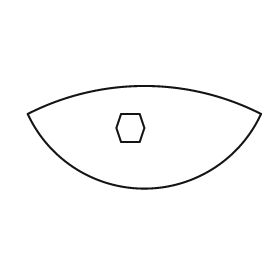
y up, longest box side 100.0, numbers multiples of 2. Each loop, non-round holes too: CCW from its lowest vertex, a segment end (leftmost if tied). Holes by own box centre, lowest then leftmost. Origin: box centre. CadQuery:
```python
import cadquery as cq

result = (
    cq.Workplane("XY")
    .moveTo(-50.0, 10.0)
    .threePointArc((0.0, -22.0), (50.0, 10.0))
    .threePointArc((0.0, 22.0), (-50.0, 10.0))
    .close()
    .moveTo(-10.0, -2.0)
    .lineTo(-2.0, -2.0)
    .lineTo(0.0, 4.0)
    .lineTo(-2.0, 10.0)
    .lineTo(-10.0, 10.0)
    .lineTo(-12.0, 4.0)
    .close()
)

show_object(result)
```